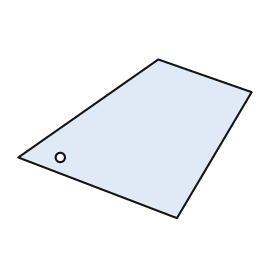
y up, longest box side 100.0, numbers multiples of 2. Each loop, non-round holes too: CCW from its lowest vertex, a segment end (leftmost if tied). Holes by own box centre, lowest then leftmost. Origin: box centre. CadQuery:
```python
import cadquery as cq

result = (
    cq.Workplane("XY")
    .moveTo(18.0, -34.0)
    .lineTo(50.0, 20.0)
    .lineTo(10.0, 34.0)
    .lineTo(-50.0, -8.0)
    .close()
    .moveTo(-32.0, -8.0)
    .circle(2.0)
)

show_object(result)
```